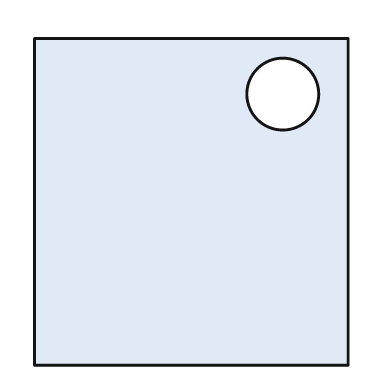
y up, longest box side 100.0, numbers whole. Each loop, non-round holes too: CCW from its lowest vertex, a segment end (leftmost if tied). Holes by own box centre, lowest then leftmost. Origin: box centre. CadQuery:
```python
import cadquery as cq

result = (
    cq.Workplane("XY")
    .moveTo(-48.0, -50.0)
    .lineTo(48.0, -50.0)
    .lineTo(48.0, 50.0)
    .lineTo(-48.0, 50.0)
    .close()
    .moveTo(28.0, 33.0)
    .circle(11.0)
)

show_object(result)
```